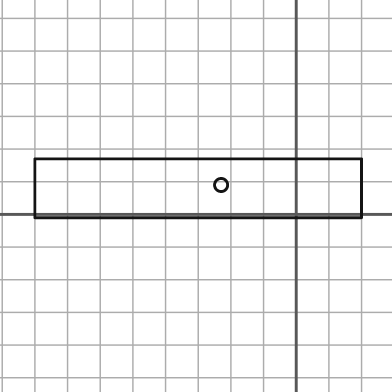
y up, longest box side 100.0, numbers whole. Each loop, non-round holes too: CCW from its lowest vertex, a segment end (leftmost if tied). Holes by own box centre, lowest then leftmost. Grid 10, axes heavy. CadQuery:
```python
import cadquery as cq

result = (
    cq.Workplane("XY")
    .moveTo(-80.0, -1.0)
    .lineTo(20.0, -1.0)
    .lineTo(20.0, 17.0)
    .lineTo(-80.0, 17.0)
    .close()
    .moveTo(-23.0, 9.0)
    .circle(2.0)
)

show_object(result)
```